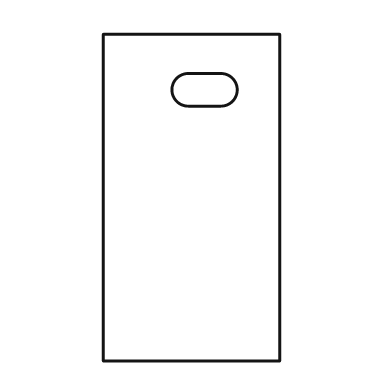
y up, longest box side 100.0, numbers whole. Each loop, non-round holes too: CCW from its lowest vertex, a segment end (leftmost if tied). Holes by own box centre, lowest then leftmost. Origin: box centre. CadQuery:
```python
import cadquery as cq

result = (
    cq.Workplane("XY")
    .moveTo(-27.0, -50.0)
    .lineTo(27.0, -50.0)
    .lineTo(27.0, 50.0)
    .lineTo(-27.0, 50.0)
    .close()
    .moveTo(-1.0, 28.0)
    .lineTo(9.0, 28.0)
    .threePointArc((14.0, 33.0), (9.0, 38.0))
    .lineTo(-1.0, 38.0)
    .threePointArc((-6.0, 33.0), (-1.0, 28.0))
    .close()
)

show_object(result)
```